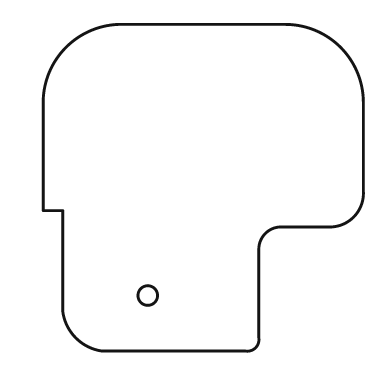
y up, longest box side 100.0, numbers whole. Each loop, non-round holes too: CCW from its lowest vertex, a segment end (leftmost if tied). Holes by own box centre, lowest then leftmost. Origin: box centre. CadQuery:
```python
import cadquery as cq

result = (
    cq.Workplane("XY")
    .moveTo(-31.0, -50.0)
    .lineTo(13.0, -50.0)
    .threePointArc((16.0, -49.0), (17.0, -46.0))
    .lineTo(17.0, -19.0)
    .threePointArc((19.0, -14.0), (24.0, -12.0))
    .lineTo(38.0, -12.0)
    .threePointArc((46.0, -9.0), (49.0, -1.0))
    .lineTo(49.0, 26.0)
    .threePointArc((42.0, 43.0), (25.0, 50.0))
    .lineTo(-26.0, 50.0)
    .threePointArc((-42.0, 43.0), (-49.0, 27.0))
    .lineTo(-49.0, -7.0)
    .lineTo(-43.0, -7.0)
    .lineTo(-43.0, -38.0)
    .threePointArc((-39.0, -46.0), (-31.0, -50.0))
    .close()
    .moveTo(-17.0, -33.0)
    .circle(3.0)
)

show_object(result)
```